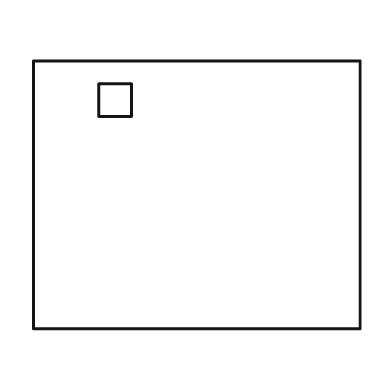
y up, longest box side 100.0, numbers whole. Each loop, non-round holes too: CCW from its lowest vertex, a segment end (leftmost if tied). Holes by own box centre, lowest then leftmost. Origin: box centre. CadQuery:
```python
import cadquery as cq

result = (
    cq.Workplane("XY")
    .moveTo(-50.0, -41.0)
    .lineTo(50.0, -41.0)
    .lineTo(50.0, 41.0)
    .lineTo(-50.0, 41.0)
    .close()
    .moveTo(-30.0, 24.0)
    .lineTo(-20.0, 24.0)
    .lineTo(-20.0, 34.0)
    .lineTo(-30.0, 34.0)
    .close()
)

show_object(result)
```